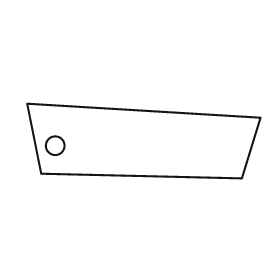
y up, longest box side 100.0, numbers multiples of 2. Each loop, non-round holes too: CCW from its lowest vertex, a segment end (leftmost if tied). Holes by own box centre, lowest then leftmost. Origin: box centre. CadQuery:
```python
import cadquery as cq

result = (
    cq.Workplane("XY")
    .moveTo(42.0, -16.0)
    .lineTo(50.0, 10.0)
    .lineTo(-50.0, 16.0)
    .lineTo(-44.0, -14.0)
    .close()
    .moveTo(-38.0, -2.0)
    .circle(4.0)
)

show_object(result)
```